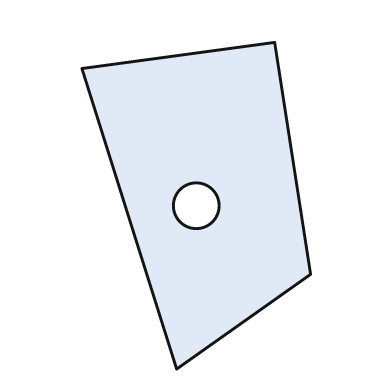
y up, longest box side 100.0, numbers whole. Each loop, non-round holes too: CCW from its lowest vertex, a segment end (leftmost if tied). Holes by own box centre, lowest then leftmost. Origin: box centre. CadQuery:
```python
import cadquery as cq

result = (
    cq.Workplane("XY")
    .moveTo(-6.0, -50.0)
    .lineTo(35.0, -21.0)
    .lineTo(24.0, 50.0)
    .lineTo(-35.0, 42.0)
    .close()
    .moveTo(0.0, 0.0)
    .circle(7.0)
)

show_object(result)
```